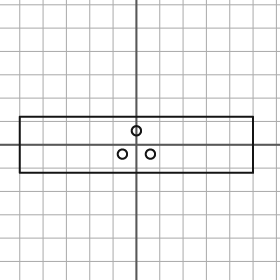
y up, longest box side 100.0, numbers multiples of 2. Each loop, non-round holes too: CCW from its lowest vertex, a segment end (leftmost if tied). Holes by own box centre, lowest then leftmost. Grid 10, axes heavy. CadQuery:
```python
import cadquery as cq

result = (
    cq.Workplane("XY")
    .moveTo(-50.0, -12.0)
    .lineTo(50.0, -12.0)
    .lineTo(50.0, 12.0)
    .lineTo(-50.0, 12.0)
    .close()
    .moveTo(-6.0, -4.0)
    .circle(2.0)
    .moveTo(6.0, -4.0)
    .circle(2.0)
    .moveTo(0.0, 6.0)
    .circle(2.0)
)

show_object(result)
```